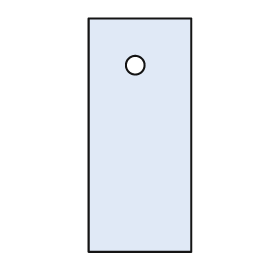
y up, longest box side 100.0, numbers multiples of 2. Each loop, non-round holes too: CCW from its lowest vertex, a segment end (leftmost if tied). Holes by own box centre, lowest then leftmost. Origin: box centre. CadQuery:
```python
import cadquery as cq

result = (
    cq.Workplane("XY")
    .moveTo(-22.0, -50.0)
    .lineTo(22.0, -50.0)
    .lineTo(22.0, 50.0)
    .lineTo(-22.0, 50.0)
    .close()
    .moveTo(-2.0, 30.0)
    .circle(4.0)
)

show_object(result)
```